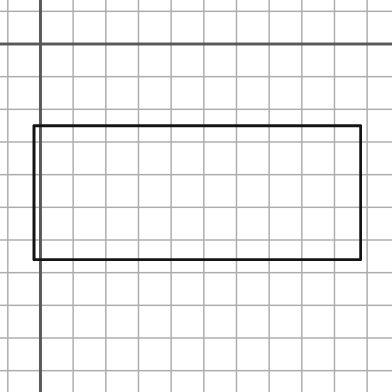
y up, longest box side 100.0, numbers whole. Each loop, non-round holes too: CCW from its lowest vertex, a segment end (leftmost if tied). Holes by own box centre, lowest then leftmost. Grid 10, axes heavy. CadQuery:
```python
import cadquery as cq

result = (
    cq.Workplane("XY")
    .moveTo(-2.0, -66.0)
    .lineTo(98.0, -66.0)
    .lineTo(98.0, -25.0)
    .lineTo(-2.0, -25.0)
    .close()
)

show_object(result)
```